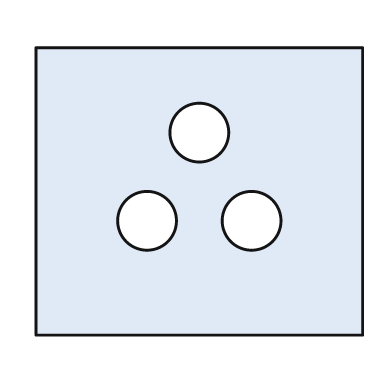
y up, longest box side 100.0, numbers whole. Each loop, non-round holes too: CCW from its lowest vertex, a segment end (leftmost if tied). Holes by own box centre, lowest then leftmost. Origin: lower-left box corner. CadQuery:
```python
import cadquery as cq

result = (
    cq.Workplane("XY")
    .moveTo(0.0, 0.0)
    .lineTo(100.0, 0.0)
    .lineTo(100.0, 88.0)
    .lineTo(0.0, 88.0)
    .close()
    .moveTo(34.0, 35.0)
    .circle(9.0)
    .moveTo(66.0, 35.0)
    .circle(9.0)
    .moveTo(50.0, 62.0)
    .circle(9.0)
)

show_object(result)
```